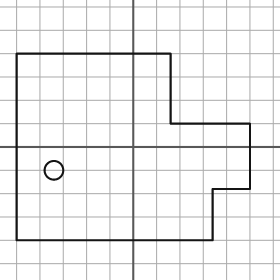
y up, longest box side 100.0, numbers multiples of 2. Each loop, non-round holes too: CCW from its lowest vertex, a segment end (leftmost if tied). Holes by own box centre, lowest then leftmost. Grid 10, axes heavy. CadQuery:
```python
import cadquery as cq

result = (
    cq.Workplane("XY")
    .moveTo(-50.0, -40.0)
    .lineTo(34.0, -40.0)
    .lineTo(34.0, -18.0)
    .lineTo(50.0, -18.0)
    .lineTo(50.0, 10.0)
    .lineTo(16.0, 10.0)
    .lineTo(16.0, 40.0)
    .lineTo(-50.0, 40.0)
    .close()
    .moveTo(-34.0, -10.0)
    .circle(4.0)
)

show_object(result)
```